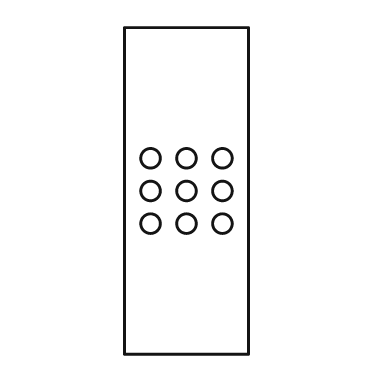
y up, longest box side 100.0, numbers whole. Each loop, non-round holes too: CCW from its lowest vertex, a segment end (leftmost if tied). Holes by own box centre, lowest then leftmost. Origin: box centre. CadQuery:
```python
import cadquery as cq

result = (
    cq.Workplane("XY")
    .moveTo(-19.0, -50.0)
    .lineTo(19.0, -50.0)
    .lineTo(19.0, 50.0)
    .lineTo(-19.0, 50.0)
    .close()
    .moveTo(-11.0, -10.0)
    .circle(3.0)
    .moveTo(0.0, -10.0)
    .circle(3.0)
    .moveTo(11.0, -10.0)
    .circle(3.0)
    .moveTo(-11.0, 0.0)
    .circle(3.0)
    .moveTo(0.0, 0.0)
    .circle(3.0)
    .moveTo(11.0, 0.0)
    .circle(3.0)
    .moveTo(-11.0, 10.0)
    .circle(3.0)
    .moveTo(0.0, 10.0)
    .circle(3.0)
    .moveTo(11.0, 10.0)
    .circle(3.0)
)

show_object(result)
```